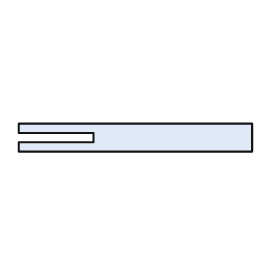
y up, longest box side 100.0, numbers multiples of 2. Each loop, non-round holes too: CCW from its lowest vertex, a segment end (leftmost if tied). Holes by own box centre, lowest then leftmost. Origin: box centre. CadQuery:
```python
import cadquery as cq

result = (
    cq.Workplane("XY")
    .moveTo(-50.0, -6.0)
    .lineTo(50.0, -6.0)
    .lineTo(50.0, 6.0)
    .lineTo(-50.0, 6.0)
    .lineTo(-50.0, 2.0)
    .lineTo(-18.0, 2.0)
    .lineTo(-18.0, -2.0)
    .lineTo(-50.0, -2.0)
    .close()
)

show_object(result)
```